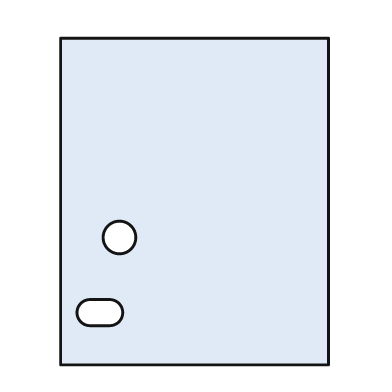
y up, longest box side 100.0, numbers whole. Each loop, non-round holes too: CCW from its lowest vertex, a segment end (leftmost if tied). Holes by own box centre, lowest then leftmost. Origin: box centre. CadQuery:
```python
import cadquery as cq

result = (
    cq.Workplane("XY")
    .moveTo(-41.0, -50.0)
    .lineTo(41.0, -50.0)
    .lineTo(41.0, 50.0)
    .lineTo(-41.0, 50.0)
    .close()
    .moveTo(-32.0, -38.0)
    .lineTo(-26.0, -38.0)
    .threePointArc((-22.0, -34.0), (-26.0, -30.0))
    .lineTo(-32.0, -30.0)
    .threePointArc((-36.0, -34.0), (-32.0, -38.0))
    .close()
    .moveTo(-23.0, -11.0)
    .circle(5.0)
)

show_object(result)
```